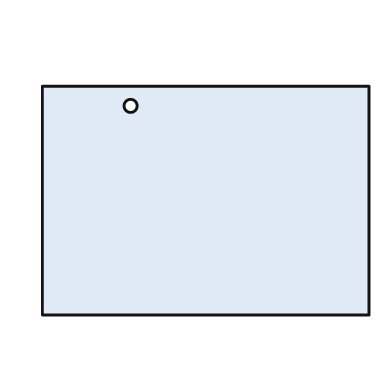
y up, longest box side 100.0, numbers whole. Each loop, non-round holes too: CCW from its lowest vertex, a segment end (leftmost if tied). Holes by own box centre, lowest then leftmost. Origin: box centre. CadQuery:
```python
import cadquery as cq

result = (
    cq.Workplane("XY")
    .moveTo(-50.0, -35.0)
    .lineTo(50.0, -35.0)
    .lineTo(50.0, 35.0)
    .lineTo(-50.0, 35.0)
    .close()
    .moveTo(-23.0, 29.0)
    .circle(2.0)
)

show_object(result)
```